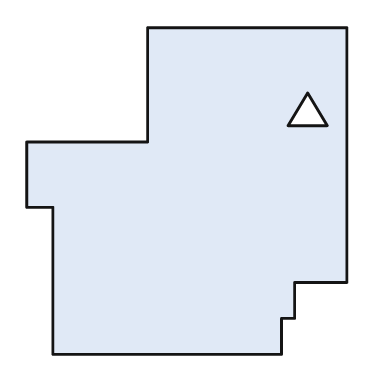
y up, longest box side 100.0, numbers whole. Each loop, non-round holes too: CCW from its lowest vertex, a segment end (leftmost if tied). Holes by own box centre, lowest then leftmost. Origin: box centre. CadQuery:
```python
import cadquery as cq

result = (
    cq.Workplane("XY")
    .moveTo(-41.0, -50.0)
    .lineTo(29.0, -50.0)
    .lineTo(29.0, -39.0)
    .lineTo(33.0, -39.0)
    .lineTo(33.0, -28.0)
    .lineTo(49.0, -28.0)
    .lineTo(49.0, 50.0)
    .lineTo(-12.0, 50.0)
    .lineTo(-12.0, 15.0)
    .lineTo(-49.0, 15.0)
    .lineTo(-49.0, -5.0)
    .lineTo(-41.0, -5.0)
    .close()
    .moveTo(31.0, 20.0)
    .lineTo(43.0, 20.0)
    .lineTo(37.0, 30.0)
    .close()
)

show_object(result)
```